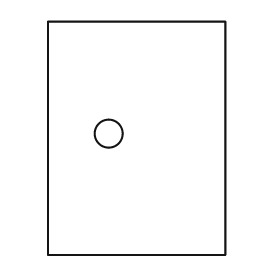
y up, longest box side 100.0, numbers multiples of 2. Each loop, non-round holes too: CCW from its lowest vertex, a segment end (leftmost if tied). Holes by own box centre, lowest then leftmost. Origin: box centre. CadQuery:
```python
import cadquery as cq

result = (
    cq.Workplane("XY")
    .moveTo(-38.0, -50.0)
    .lineTo(38.0, -50.0)
    .lineTo(38.0, 50.0)
    .lineTo(-38.0, 50.0)
    .close()
    .moveTo(-12.0, 2.0)
    .circle(6.0)
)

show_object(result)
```